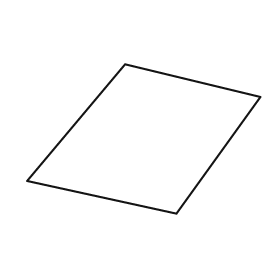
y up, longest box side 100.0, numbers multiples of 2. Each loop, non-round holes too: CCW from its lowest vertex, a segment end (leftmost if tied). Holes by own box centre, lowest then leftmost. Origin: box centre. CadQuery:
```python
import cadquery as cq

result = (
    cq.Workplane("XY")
    .moveTo(14.0, -32.0)
    .lineTo(50.0, 18.0)
    .lineTo(-8.0, 32.0)
    .lineTo(-50.0, -18.0)
    .close()
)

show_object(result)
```